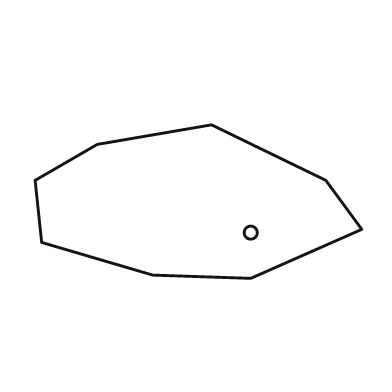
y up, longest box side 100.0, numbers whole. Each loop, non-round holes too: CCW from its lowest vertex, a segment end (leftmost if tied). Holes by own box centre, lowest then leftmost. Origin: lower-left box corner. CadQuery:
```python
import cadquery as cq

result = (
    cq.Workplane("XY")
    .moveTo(66.0, 0.0)
    .lineTo(100.0, 15.0)
    .lineTo(89.0, 30.0)
    .lineTo(54.0, 47.0)
    .lineTo(19.0, 41.0)
    .lineTo(0.0, 30.0)
    .lineTo(2.0, 11.0)
    .lineTo(36.0, 1.0)
    .close()
    .moveTo(66.0, 14.0)
    .circle(2.0)
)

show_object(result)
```